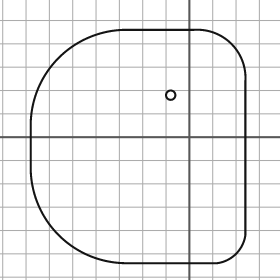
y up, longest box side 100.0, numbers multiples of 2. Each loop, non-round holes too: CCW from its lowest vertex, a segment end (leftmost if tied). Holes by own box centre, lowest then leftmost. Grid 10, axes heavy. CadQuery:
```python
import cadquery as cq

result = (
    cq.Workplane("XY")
    .moveTo(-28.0, -54.0)
    .lineTo(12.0, -54.0)
    .threePointArc((20.0, -50.0), (24.0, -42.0))
    .lineTo(24.0, 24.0)
    .threePointArc((18.0, 40.0), (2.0, 46.0))
    .lineTo(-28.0, 46.0)
    .threePointArc((-56.0, 34.0), (-68.0, 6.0))
    .lineTo(-68.0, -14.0)
    .threePointArc((-56.0, -42.0), (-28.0, -54.0))
    .close()
    .moveTo(-8.0, 18.0)
    .circle(2.0)
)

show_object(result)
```